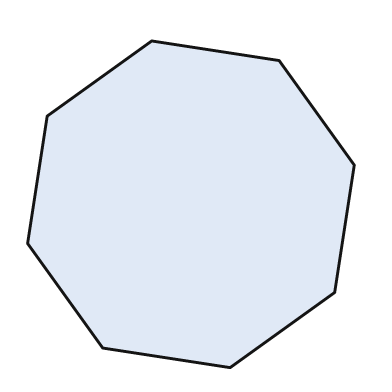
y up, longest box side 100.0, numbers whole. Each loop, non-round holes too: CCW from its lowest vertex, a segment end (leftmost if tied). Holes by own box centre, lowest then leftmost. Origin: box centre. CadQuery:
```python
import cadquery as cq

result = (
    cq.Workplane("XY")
    .moveTo(12.0, -50.0)
    .lineTo(44.0, -27.0)
    .lineTo(50.0, 12.0)
    .lineTo(27.0, 44.0)
    .lineTo(-12.0, 50.0)
    .lineTo(-44.0, 27.0)
    .lineTo(-50.0, -12.0)
    .lineTo(-27.0, -44.0)
    .close()
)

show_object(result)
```